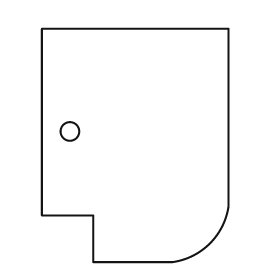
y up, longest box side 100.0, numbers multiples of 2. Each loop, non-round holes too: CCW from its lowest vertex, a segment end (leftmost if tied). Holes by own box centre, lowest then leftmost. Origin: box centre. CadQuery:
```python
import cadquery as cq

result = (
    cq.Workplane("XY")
    .moveTo(-18.0, -50.0)
    .lineTo(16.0, -50.0)
    .threePointArc((32.0, -42.0), (40.0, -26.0))
    .lineTo(40.0, 50.0)
    .lineTo(-40.0, 50.0)
    .lineTo(-40.0, -30.0)
    .lineTo(-18.0, -30.0)
    .close()
    .moveTo(-28.0, 6.0)
    .circle(4.0)
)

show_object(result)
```